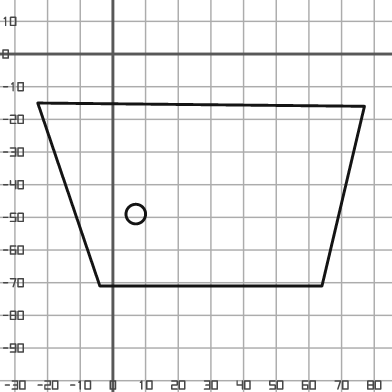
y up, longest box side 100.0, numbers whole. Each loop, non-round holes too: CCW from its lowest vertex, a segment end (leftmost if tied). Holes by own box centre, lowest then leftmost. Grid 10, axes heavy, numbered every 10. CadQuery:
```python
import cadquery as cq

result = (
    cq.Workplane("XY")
    .moveTo(-4.0, -71.0)
    .lineTo(64.0, -71.0)
    .lineTo(77.0, -16.0)
    .lineTo(-23.0, -15.0)
    .close()
    .moveTo(7.0, -49.0)
    .circle(3.0)
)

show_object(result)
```